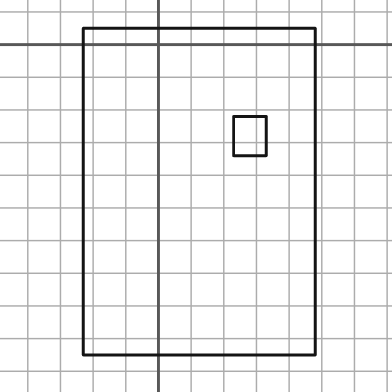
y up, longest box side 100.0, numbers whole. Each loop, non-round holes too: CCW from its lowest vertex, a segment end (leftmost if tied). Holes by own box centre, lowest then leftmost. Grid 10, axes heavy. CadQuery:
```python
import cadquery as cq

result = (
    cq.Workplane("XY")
    .moveTo(-23.0, -95.0)
    .lineTo(48.0, -95.0)
    .lineTo(48.0, 5.0)
    .lineTo(-23.0, 5.0)
    .close()
    .moveTo(23.0, -34.0)
    .lineTo(33.0, -34.0)
    .lineTo(33.0, -22.0)
    .lineTo(23.0, -22.0)
    .close()
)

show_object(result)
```